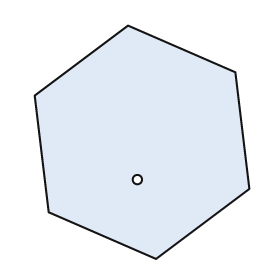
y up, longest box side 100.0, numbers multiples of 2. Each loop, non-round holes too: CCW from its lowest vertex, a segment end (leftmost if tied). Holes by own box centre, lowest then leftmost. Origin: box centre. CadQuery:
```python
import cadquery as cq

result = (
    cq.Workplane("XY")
    .moveTo(6.0, -50.0)
    .lineTo(46.0, -20.0)
    .lineTo(40.0, 30.0)
    .lineTo(-6.0, 50.0)
    .lineTo(-46.0, 20.0)
    .lineTo(-40.0, -30.0)
    .close()
    .moveTo(-2.0, -16.0)
    .circle(2.0)
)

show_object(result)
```